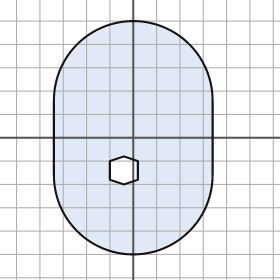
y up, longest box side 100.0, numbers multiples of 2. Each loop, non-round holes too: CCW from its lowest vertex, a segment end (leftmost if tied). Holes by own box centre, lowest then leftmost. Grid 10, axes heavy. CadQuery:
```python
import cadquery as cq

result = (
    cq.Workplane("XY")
    .moveTo(-34.0, -16.0)
    .threePointArc((0.0, -50.0), (34.0, -16.0))
    .lineTo(34.0, 16.0)
    .threePointArc((0.0, 50.0), (-34.0, 16.0))
    .close()
    .moveTo(-4.0, -20.0)
    .lineTo(2.0, -18.0)
    .lineTo(2.0, -10.0)
    .lineTo(-4.0, -8.0)
    .lineTo(-10.0, -10.0)
    .lineTo(-10.0, -18.0)
    .close()
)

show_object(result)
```